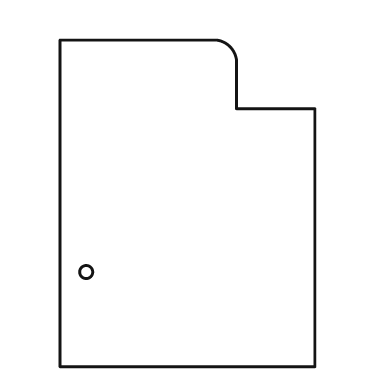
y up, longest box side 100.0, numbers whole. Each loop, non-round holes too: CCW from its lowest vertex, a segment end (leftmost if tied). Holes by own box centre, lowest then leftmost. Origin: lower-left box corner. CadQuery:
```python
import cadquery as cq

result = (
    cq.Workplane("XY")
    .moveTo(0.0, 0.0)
    .lineTo(78.0, 0.0)
    .lineTo(78.0, 79.0)
    .lineTo(54.0, 79.0)
    .lineTo(54.0, 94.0)
    .threePointArc((52.0, 98.0), (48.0, 100.0))
    .lineTo(0.0, 100.0)
    .close()
    .moveTo(8.0, 29.0)
    .circle(2.0)
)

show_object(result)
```